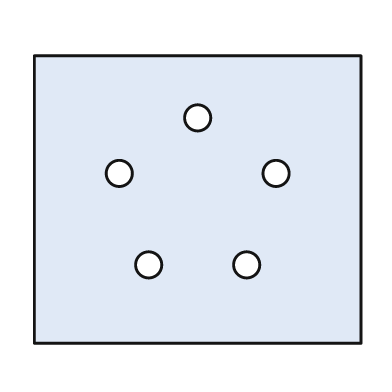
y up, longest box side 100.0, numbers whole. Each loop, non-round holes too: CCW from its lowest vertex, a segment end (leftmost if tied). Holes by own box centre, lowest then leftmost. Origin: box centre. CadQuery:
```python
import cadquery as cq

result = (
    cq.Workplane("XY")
    .moveTo(-50.0, -44.0)
    .lineTo(50.0, -44.0)
    .lineTo(50.0, 44.0)
    .lineTo(-50.0, 44.0)
    .close()
    .moveTo(-15.0, -20.0)
    .circle(4.0)
    .moveTo(15.0, -20.0)
    .circle(4.0)
    .moveTo(-24.0, 8.0)
    .circle(4.0)
    .moveTo(24.0, 8.0)
    .circle(4.0)
    .moveTo(0.0, 25.0)
    .circle(4.0)
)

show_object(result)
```